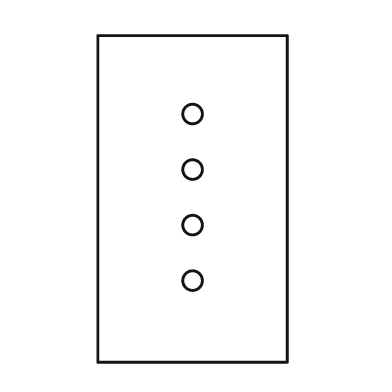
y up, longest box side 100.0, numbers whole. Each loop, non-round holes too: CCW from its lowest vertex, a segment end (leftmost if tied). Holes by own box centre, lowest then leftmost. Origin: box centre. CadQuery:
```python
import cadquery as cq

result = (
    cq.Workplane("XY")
    .moveTo(-29.0, -50.0)
    .lineTo(29.0, -50.0)
    .lineTo(29.0, 50.0)
    .lineTo(-29.0, 50.0)
    .close()
    .moveTo(0.0, -25.0)
    .circle(3.0)
    .moveTo(0.0, -8.0)
    .circle(3.0)
    .moveTo(0.0, 9.0)
    .circle(3.0)
    .moveTo(0.0, 26.0)
    .circle(3.0)
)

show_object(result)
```